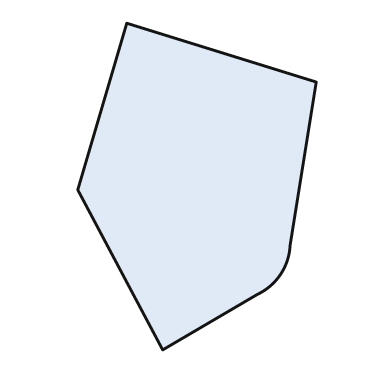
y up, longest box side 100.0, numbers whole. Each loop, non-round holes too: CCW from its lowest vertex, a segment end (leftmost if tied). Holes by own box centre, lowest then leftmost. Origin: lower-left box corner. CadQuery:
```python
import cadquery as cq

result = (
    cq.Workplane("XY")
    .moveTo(26.0, 0.0)
    .lineTo(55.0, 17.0)
    .threePointArc((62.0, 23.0), (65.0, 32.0))
    .lineTo(73.0, 82.0)
    .lineTo(15.0, 100.0)
    .lineTo(0.0, 49.0)
    .close()
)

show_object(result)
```